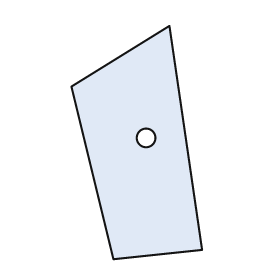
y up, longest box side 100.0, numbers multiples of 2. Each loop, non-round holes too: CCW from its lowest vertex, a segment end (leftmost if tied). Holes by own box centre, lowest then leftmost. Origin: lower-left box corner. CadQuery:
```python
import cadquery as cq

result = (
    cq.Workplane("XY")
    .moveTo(18.0, 0.0)
    .lineTo(56.0, 4.0)
    .lineTo(42.0, 100.0)
    .lineTo(0.0, 74.0)
    .close()
    .moveTo(32.0, 52.0)
    .circle(4.0)
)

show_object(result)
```